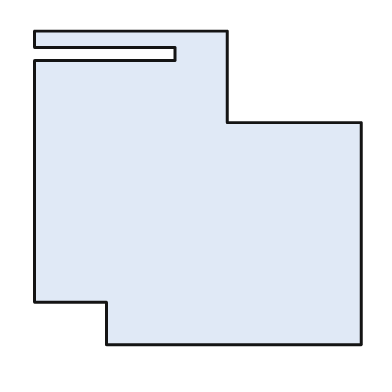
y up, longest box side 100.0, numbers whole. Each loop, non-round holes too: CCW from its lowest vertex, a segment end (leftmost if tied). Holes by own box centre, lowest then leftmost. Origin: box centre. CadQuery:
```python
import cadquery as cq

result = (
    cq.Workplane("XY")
    .moveTo(-28.0, -48.0)
    .lineTo(50.0, -48.0)
    .lineTo(50.0, 20.0)
    .lineTo(9.0, 20.0)
    .lineTo(9.0, 48.0)
    .lineTo(-50.0, 48.0)
    .lineTo(-50.0, 43.0)
    .lineTo(-7.0, 43.0)
    .lineTo(-7.0, 39.0)
    .lineTo(-50.0, 39.0)
    .lineTo(-50.0, -35.0)
    .lineTo(-28.0, -35.0)
    .close()
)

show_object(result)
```